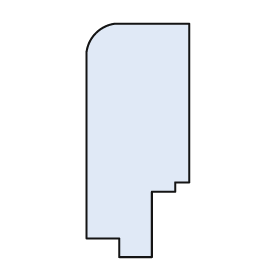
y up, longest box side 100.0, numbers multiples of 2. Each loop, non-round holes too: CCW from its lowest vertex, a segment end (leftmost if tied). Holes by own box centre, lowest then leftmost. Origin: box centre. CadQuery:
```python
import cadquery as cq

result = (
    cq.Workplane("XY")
    .moveTo(-8.0, -50.0)
    .lineTo(6.0, -50.0)
    .lineTo(6.0, -22.0)
    .lineTo(16.0, -22.0)
    .lineTo(16.0, -18.0)
    .lineTo(22.0, -18.0)
    .lineTo(22.0, 50.0)
    .lineTo(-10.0, 50.0)
    .threePointArc((-18.0, 46.0), (-22.0, 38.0))
    .lineTo(-22.0, -42.0)
    .lineTo(-8.0, -42.0)
    .close()
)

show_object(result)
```